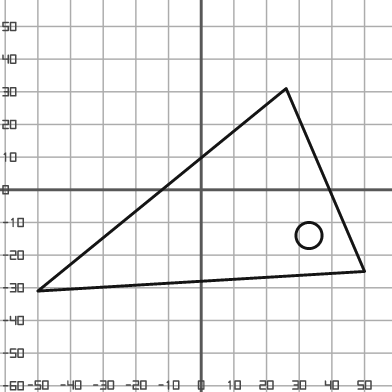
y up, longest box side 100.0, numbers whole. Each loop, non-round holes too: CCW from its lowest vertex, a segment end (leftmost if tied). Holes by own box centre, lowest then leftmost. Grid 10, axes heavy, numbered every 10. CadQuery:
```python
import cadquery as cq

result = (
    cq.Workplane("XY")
    .moveTo(-50.0, -31.0)
    .lineTo(50.0, -25.0)
    .lineTo(26.0, 31.0)
    .close()
    .moveTo(33.0, -14.0)
    .circle(4.0)
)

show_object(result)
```